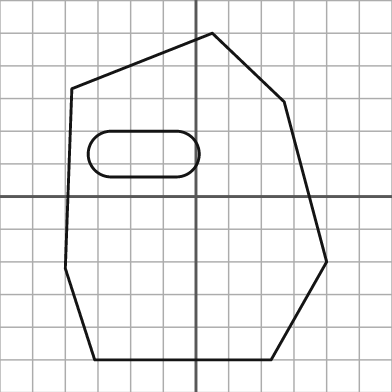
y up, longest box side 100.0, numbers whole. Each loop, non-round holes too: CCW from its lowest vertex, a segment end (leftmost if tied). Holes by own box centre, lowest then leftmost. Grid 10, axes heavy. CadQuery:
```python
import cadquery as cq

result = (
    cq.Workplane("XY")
    .moveTo(-31.0, -50.0)
    .lineTo(23.0, -50.0)
    .lineTo(40.0, -20.0)
    .lineTo(27.0, 29.0)
    .lineTo(5.0, 50.0)
    .lineTo(-38.0, 33.0)
    .lineTo(-40.0, -22.0)
    .close()
    .moveTo(-26.0, 6.0)
    .lineTo(-6.0, 6.0)
    .threePointArc((1.0, 13.0), (-6.0, 20.0))
    .lineTo(-26.0, 20.0)
    .threePointArc((-33.0, 13.0), (-26.0, 6.0))
    .close()
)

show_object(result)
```